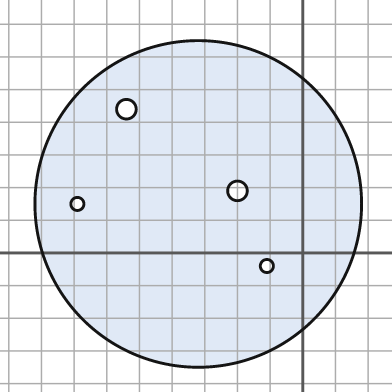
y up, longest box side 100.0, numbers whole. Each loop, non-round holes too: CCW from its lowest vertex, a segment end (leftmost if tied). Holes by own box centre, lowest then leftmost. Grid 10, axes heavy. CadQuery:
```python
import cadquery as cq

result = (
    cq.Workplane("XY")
    .moveTo(-32.0, 15.0)
    .circle(50.0)
    .moveTo(-11.0, -4.0)
    .circle(2.0)
    .moveTo(-69.0, 15.0)
    .circle(2.0)
    .moveTo(-20.0, 19.0)
    .circle(3.0)
    .moveTo(-54.0, 44.0)
    .circle(3.0)
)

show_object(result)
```